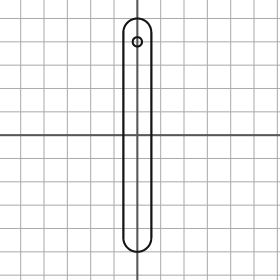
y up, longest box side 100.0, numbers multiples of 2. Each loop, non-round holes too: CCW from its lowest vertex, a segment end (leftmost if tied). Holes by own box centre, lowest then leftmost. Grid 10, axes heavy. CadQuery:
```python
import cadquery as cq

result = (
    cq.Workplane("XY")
    .moveTo(-6.0, -44.0)
    .threePointArc((0.0, -50.0), (6.0, -44.0))
    .lineTo(6.0, 44.0)
    .threePointArc((0.0, 50.0), (-6.0, 44.0))
    .close()
    .moveTo(0.0, 40.0)
    .circle(2.0)
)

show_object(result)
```